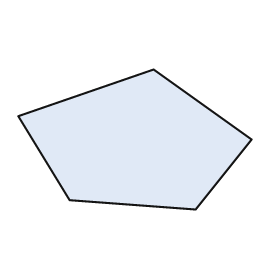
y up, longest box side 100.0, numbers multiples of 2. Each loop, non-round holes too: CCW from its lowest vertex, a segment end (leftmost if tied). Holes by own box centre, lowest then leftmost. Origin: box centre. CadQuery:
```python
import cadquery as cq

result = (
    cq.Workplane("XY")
    .moveTo(26.0, -30.0)
    .lineTo(50.0, 0.0)
    .lineTo(8.0, 30.0)
    .lineTo(-50.0, 10.0)
    .lineTo(-28.0, -26.0)
    .close()
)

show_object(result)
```